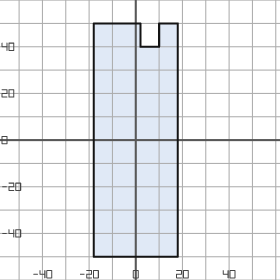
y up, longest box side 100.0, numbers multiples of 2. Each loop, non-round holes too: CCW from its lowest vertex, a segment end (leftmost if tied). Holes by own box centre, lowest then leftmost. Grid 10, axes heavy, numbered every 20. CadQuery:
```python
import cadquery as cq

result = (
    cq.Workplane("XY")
    .moveTo(-18.0, -50.0)
    .lineTo(18.0, -50.0)
    .lineTo(18.0, 50.0)
    .lineTo(10.0, 50.0)
    .lineTo(10.0, 40.0)
    .lineTo(2.0, 40.0)
    .lineTo(2.0, 50.0)
    .lineTo(-18.0, 50.0)
    .close()
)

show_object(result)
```